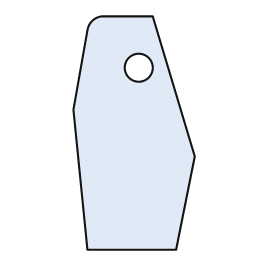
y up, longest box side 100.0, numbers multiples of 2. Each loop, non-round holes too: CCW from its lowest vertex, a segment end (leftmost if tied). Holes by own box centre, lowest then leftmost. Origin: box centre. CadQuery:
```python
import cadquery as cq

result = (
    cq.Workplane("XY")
    .moveTo(-20.0, -50.0)
    .lineTo(18.0, -50.0)
    .lineTo(26.0, -10.0)
    .lineTo(8.0, 50.0)
    .lineTo(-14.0, 50.0)
    .threePointArc((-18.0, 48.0), (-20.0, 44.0))
    .lineTo(-26.0, 10.0)
    .close()
    .moveTo(2.0, 28.0)
    .circle(6.0)
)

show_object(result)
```